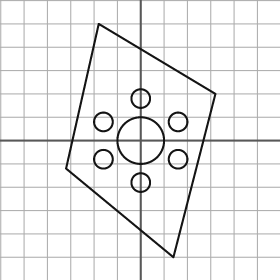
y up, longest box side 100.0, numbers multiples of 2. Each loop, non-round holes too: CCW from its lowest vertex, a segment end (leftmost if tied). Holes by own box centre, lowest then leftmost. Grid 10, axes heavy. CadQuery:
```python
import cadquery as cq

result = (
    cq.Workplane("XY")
    .moveTo(14.0, -50.0)
    .lineTo(32.0, 20.0)
    .lineTo(-18.0, 50.0)
    .lineTo(-32.0, -12.0)
    .close()
    .moveTo(0.0, -18.0)
    .circle(4.0)
    .moveTo(-16.0, -8.0)
    .circle(4.0)
    .moveTo(16.0, -8.0)
    .circle(4.0)
    .moveTo(0.0, 0.0)
    .circle(10.0)
    .moveTo(-16.0, 8.0)
    .circle(4.0)
    .moveTo(16.0, 8.0)
    .circle(4.0)
    .moveTo(0.0, 18.0)
    .circle(4.0)
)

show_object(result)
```